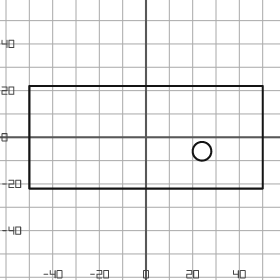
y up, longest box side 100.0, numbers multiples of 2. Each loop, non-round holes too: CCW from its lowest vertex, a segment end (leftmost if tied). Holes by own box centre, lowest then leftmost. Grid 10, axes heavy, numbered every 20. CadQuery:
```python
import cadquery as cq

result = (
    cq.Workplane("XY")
    .moveTo(-50.0, -22.0)
    .lineTo(50.0, -22.0)
    .lineTo(50.0, 22.0)
    .lineTo(-50.0, 22.0)
    .close()
    .moveTo(24.0, -6.0)
    .circle(4.0)
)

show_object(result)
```